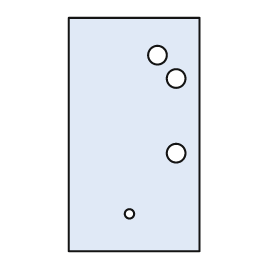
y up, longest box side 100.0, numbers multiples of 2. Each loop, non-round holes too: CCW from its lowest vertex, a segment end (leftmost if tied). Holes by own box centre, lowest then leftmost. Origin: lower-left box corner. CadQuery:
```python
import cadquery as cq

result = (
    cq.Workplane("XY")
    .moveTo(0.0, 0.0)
    .lineTo(56.0, 0.0)
    .lineTo(56.0, 100.0)
    .lineTo(0.0, 100.0)
    .close()
    .moveTo(26.0, 16.0)
    .circle(2.0)
    .moveTo(46.0, 42.0)
    .circle(4.0)
    .moveTo(46.0, 74.0)
    .circle(4.0)
    .moveTo(38.0, 84.0)
    .circle(4.0)
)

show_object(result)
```